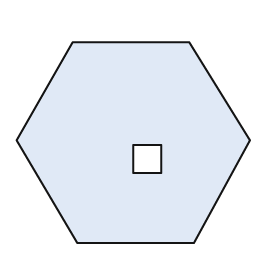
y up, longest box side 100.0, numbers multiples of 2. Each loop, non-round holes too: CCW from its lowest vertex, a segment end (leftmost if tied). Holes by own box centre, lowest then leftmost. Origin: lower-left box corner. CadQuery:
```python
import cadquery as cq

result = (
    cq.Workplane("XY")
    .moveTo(26.0, 0.0)
    .lineTo(76.0, 0.0)
    .lineTo(100.0, 44.0)
    .lineTo(74.0, 86.0)
    .lineTo(24.0, 86.0)
    .lineTo(0.0, 44.0)
    .close()
    .moveTo(50.0, 30.0)
    .lineTo(62.0, 30.0)
    .lineTo(62.0, 42.0)
    .lineTo(50.0, 42.0)
    .close()
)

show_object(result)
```